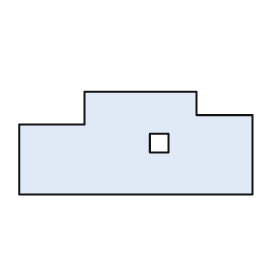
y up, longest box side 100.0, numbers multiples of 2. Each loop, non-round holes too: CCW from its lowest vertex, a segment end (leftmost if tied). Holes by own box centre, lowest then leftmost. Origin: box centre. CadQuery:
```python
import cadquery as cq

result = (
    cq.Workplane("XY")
    .moveTo(-50.0, -22.0)
    .lineTo(50.0, -22.0)
    .lineTo(50.0, 12.0)
    .lineTo(26.0, 12.0)
    .lineTo(26.0, 22.0)
    .lineTo(-22.0, 22.0)
    .lineTo(-22.0, 8.0)
    .lineTo(-50.0, 8.0)
    .close()
    .moveTo(6.0, -4.0)
    .lineTo(14.0, -4.0)
    .lineTo(14.0, 4.0)
    .lineTo(6.0, 4.0)
    .close()
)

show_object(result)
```